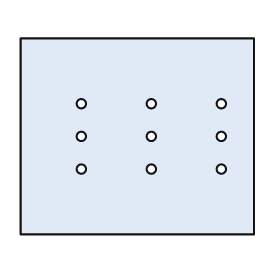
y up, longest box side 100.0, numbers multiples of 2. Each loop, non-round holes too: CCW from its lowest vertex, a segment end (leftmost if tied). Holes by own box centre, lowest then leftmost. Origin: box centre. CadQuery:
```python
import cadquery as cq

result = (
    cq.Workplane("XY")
    .moveTo(-50.0, -42.0)
    .lineTo(50.0, -42.0)
    .lineTo(50.0, 42.0)
    .lineTo(-50.0, 42.0)
    .close()
    .moveTo(-24.0, -14.0)
    .circle(2.0)
    .moveTo(6.0, -14.0)
    .circle(2.0)
    .moveTo(36.0, -14.0)
    .circle(2.0)
    .moveTo(-24.0, 0.0)
    .circle(2.0)
    .moveTo(6.0, 0.0)
    .circle(2.0)
    .moveTo(36.0, 0.0)
    .circle(2.0)
    .moveTo(-24.0, 14.0)
    .circle(2.0)
    .moveTo(6.0, 14.0)
    .circle(2.0)
    .moveTo(36.0, 14.0)
    .circle(2.0)
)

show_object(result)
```